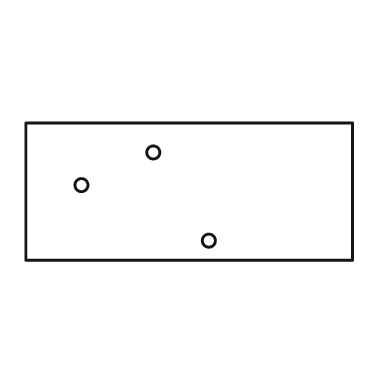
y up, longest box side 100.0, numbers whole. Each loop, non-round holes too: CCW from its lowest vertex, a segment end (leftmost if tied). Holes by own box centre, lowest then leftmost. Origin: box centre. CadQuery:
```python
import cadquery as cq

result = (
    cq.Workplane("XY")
    .moveTo(-50.0, -21.0)
    .lineTo(50.0, -21.0)
    .lineTo(50.0, 21.0)
    .lineTo(-50.0, 21.0)
    .close()
    .moveTo(6.0, -15.0)
    .circle(2.0)
    .moveTo(-33.0, 2.0)
    .circle(2.0)
    .moveTo(-11.0, 12.0)
    .circle(2.0)
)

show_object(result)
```